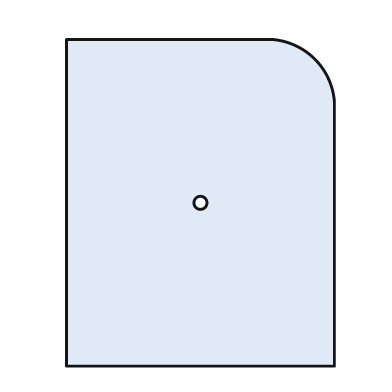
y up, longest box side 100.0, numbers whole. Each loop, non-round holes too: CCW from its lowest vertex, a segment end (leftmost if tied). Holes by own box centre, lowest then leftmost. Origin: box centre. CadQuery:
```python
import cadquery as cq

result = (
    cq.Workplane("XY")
    .moveTo(-41.0, -50.0)
    .lineTo(41.0, -50.0)
    .lineTo(41.0, 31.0)
    .threePointArc((35.0, 44.0), (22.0, 50.0))
    .lineTo(-41.0, 50.0)
    .close()
    .moveTo(0.0, 0.0)
    .circle(2.0)
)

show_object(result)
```